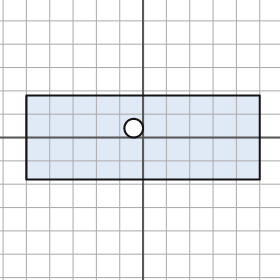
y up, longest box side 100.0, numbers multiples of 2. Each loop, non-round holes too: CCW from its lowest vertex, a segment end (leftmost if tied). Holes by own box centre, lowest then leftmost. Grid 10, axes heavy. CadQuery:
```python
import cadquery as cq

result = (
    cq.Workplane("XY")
    .moveTo(-50.0, -18.0)
    .lineTo(50.0, -18.0)
    .lineTo(50.0, 18.0)
    .lineTo(-50.0, 18.0)
    .close()
    .moveTo(-4.0, 4.0)
    .circle(4.0)
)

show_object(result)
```